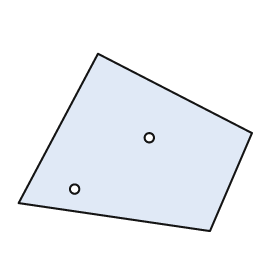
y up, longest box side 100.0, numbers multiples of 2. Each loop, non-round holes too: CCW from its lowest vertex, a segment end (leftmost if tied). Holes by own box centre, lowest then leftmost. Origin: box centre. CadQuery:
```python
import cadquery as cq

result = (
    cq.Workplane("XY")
    .moveTo(32.0, -38.0)
    .lineTo(50.0, 4.0)
    .lineTo(-16.0, 38.0)
    .lineTo(-50.0, -26.0)
    .close()
    .moveTo(-26.0, -20.0)
    .circle(2.0)
    .moveTo(6.0, 2.0)
    .circle(2.0)
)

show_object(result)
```